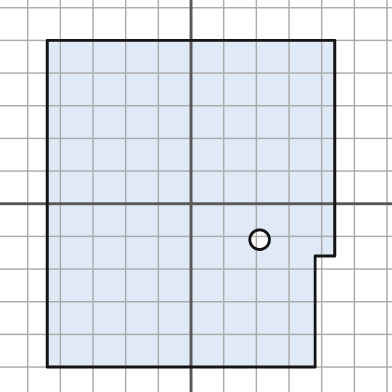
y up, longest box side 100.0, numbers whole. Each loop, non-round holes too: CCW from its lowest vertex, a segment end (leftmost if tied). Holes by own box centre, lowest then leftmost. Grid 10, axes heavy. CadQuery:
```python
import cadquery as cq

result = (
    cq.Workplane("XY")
    .moveTo(-44.0, -50.0)
    .lineTo(38.0, -50.0)
    .lineTo(38.0, -16.0)
    .lineTo(44.0, -16.0)
    .lineTo(44.0, 50.0)
    .lineTo(-44.0, 50.0)
    .close()
    .moveTo(21.0, -11.0)
    .circle(3.0)
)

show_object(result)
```